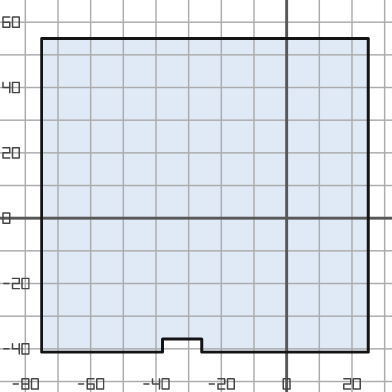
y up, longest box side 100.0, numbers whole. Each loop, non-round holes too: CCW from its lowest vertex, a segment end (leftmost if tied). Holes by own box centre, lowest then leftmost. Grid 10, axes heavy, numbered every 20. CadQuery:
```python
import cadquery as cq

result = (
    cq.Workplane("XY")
    .moveTo(-75.0, -41.0)
    .lineTo(-38.0, -41.0)
    .lineTo(-38.0, -37.0)
    .lineTo(-26.0, -37.0)
    .lineTo(-26.0, -41.0)
    .lineTo(25.0, -41.0)
    .lineTo(25.0, 55.0)
    .lineTo(-75.0, 55.0)
    .close()
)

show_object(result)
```